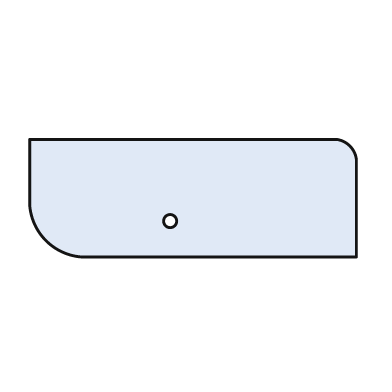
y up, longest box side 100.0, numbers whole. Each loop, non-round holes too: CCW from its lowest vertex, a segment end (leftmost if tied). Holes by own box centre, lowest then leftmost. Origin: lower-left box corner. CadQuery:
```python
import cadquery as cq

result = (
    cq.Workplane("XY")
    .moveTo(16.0, 0.0)
    .lineTo(100.0, 0.0)
    .lineTo(100.0, 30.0)
    .threePointArc((98.0, 34.0), (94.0, 36.0))
    .lineTo(0.0, 36.0)
    .lineTo(0.0, 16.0)
    .threePointArc((5.0, 5.0), (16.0, 0.0))
    .close()
    .moveTo(43.0, 11.0)
    .circle(2.0)
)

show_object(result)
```